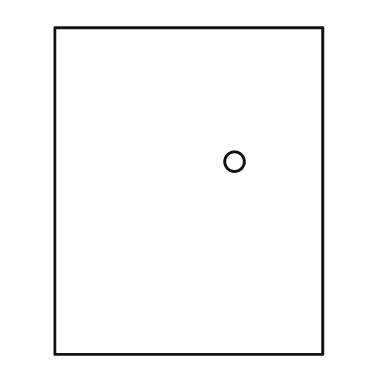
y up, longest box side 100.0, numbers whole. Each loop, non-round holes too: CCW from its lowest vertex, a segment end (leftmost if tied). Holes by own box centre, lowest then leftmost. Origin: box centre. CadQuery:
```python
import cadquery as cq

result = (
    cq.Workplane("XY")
    .moveTo(-41.0, -50.0)
    .lineTo(41.0, -50.0)
    .lineTo(41.0, 50.0)
    .lineTo(-41.0, 50.0)
    .close()
    .moveTo(14.0, 9.0)
    .circle(3.0)
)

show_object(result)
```